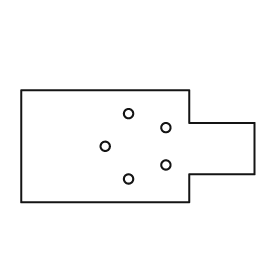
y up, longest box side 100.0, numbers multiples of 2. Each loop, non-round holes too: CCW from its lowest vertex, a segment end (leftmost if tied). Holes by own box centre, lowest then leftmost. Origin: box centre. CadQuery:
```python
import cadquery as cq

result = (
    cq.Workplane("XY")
    .moveTo(-50.0, -24.0)
    .lineTo(22.0, -24.0)
    .lineTo(22.0, -12.0)
    .lineTo(50.0, -12.0)
    .lineTo(50.0, 10.0)
    .lineTo(22.0, 10.0)
    .lineTo(22.0, 24.0)
    .lineTo(-50.0, 24.0)
    .close()
    .moveTo(-4.0, -14.0)
    .circle(2.0)
    .moveTo(12.0, -8.0)
    .circle(2.0)
    .moveTo(-14.0, 0.0)
    .circle(2.0)
    .moveTo(12.0, 8.0)
    .circle(2.0)
    .moveTo(-4.0, 14.0)
    .circle(2.0)
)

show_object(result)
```